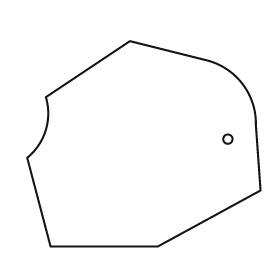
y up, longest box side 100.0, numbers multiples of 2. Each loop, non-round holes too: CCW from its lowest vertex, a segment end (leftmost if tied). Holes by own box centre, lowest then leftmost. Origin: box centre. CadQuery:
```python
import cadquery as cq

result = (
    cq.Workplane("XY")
    .moveTo(-40.0, -44.0)
    .lineTo(6.0, -44.0)
    .lineTo(50.0, -20.0)
    .lineTo(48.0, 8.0)
    .threePointArc((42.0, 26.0), (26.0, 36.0))
    .lineTo(-6.0, 44.0)
    .lineTo(-42.0, 20.0)
    .threePointArc((-42.0, 6.0), (-50.0, -6.0))
    .close()
    .moveTo(36.0, 2.0)
    .circle(2.0)
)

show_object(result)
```